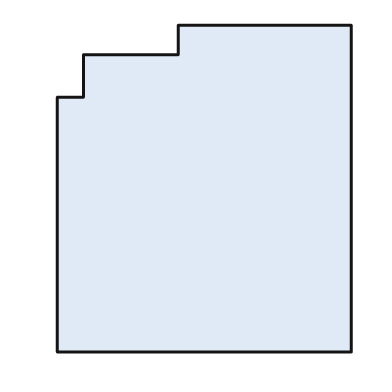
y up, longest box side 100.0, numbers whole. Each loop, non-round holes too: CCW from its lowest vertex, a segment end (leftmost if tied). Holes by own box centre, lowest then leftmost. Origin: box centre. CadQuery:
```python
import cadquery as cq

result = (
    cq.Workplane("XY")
    .moveTo(-45.0, -50.0)
    .lineTo(45.0, -50.0)
    .lineTo(45.0, 50.0)
    .lineTo(-8.0, 50.0)
    .lineTo(-8.0, 41.0)
    .lineTo(-37.0, 41.0)
    .lineTo(-37.0, 28.0)
    .lineTo(-45.0, 28.0)
    .close()
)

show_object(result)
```